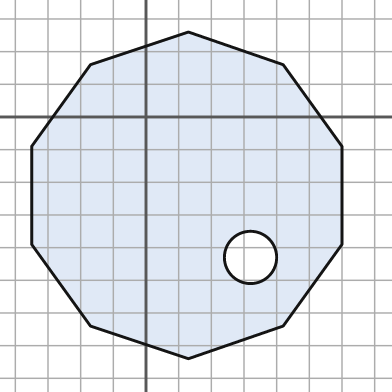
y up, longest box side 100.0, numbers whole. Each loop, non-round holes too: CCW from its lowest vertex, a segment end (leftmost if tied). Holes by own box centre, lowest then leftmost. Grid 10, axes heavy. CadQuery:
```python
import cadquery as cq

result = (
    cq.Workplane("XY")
    .moveTo(13.0, -74.0)
    .lineTo(42.0, -64.0)
    .lineTo(60.0, -39.0)
    .lineTo(60.0, -9.0)
    .lineTo(42.0, 16.0)
    .lineTo(13.0, 26.0)
    .lineTo(-17.0, 16.0)
    .lineTo(-35.0, -9.0)
    .lineTo(-35.0, -39.0)
    .lineTo(-17.0, -64.0)
    .close()
    .moveTo(32.0, -43.0)
    .circle(8.0)
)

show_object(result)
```